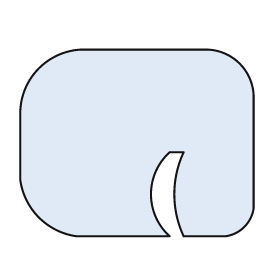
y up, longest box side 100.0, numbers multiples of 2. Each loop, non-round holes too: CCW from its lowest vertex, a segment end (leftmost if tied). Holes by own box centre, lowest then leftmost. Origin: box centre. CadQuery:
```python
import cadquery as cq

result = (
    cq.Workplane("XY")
    .moveTo(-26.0, -40.0)
    .lineTo(14.0, -40.0)
    .threePointArc((6.0, -22.0), (14.0, -4.0))
    .lineTo(20.0, -4.0)
    .threePointArc((16.0, -22.0), (20.0, -40.0))
    .lineTo(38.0, -40.0)
    .threePointArc((46.0, -36.0), (50.0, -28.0))
    .lineTo(50.0, 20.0)
    .threePointArc((44.0, 34.0), (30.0, 40.0))
    .lineTo(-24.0, 40.0)
    .threePointArc((-42.0, 32.0), (-50.0, 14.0))
    .lineTo(-50.0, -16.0)
    .threePointArc((-42.0, -32.0), (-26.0, -40.0))
    .close()
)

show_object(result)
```